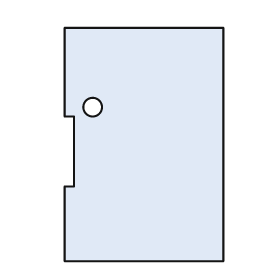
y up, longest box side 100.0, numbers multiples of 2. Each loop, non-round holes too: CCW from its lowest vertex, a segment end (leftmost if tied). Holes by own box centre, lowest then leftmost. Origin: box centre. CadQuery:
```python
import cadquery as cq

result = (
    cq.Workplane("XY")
    .moveTo(-34.0, -50.0)
    .lineTo(34.0, -50.0)
    .lineTo(34.0, 50.0)
    .lineTo(-34.0, 50.0)
    .lineTo(-34.0, 12.0)
    .lineTo(-30.0, 12.0)
    .lineTo(-30.0, -18.0)
    .lineTo(-34.0, -18.0)
    .close()
    .moveTo(-22.0, 16.0)
    .circle(4.0)
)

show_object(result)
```